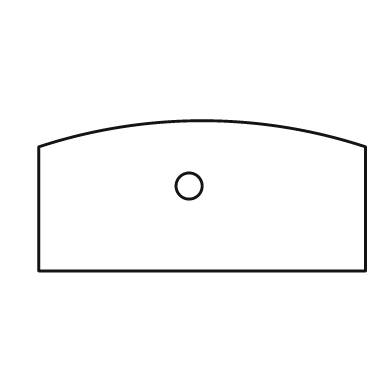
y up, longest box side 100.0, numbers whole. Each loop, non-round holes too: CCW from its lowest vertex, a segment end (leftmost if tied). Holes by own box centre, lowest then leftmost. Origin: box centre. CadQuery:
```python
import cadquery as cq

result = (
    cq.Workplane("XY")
    .moveTo(-50.0, -23.0)
    .lineTo(50.0, -23.0)
    .lineTo(50.0, 15.0)
    .threePointArc((0.0, 23.0), (-50.0, 15.0))
    .close()
    .moveTo(-4.0, 3.0)
    .circle(4.0)
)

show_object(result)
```